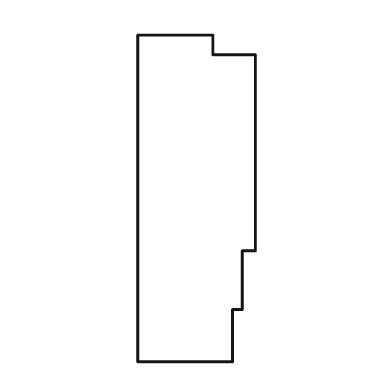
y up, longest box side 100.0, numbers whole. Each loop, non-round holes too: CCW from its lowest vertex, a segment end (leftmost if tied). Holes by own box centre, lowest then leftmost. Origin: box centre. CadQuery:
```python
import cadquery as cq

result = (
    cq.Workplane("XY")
    .moveTo(-18.0, -50.0)
    .lineTo(11.0, -50.0)
    .lineTo(11.0, -34.0)
    .lineTo(14.0, -34.0)
    .lineTo(14.0, -16.0)
    .lineTo(18.0, -16.0)
    .lineTo(18.0, 44.0)
    .lineTo(5.0, 44.0)
    .lineTo(5.0, 50.0)
    .lineTo(-18.0, 50.0)
    .close()
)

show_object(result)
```